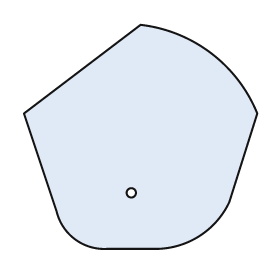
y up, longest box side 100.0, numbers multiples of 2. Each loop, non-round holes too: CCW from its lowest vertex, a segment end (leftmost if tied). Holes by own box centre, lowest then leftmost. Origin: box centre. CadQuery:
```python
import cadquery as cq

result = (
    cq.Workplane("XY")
    .moveTo(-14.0, -48.0)
    .lineTo(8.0, -48.0)
    .threePointArc((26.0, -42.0), (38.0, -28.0))
    .lineTo(50.0, 10.0)
    .threePointArc((30.0, 36.0), (0.0, 48.0))
    .lineTo(-50.0, 10.0)
    .lineTo(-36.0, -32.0)
    .threePointArc((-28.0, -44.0), (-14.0, -48.0))
    .close()
    .moveTo(-4.0, -24.0)
    .circle(2.0)
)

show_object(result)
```